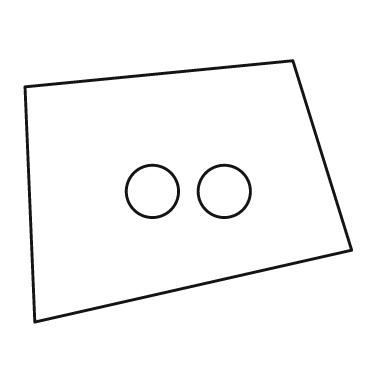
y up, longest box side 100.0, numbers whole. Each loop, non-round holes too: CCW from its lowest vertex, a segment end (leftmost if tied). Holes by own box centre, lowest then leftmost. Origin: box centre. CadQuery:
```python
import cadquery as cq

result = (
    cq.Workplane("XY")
    .moveTo(-47.0, -40.0)
    .lineTo(50.0, -18.0)
    .lineTo(32.0, 40.0)
    .lineTo(-50.0, 32.0)
    .close()
    .moveTo(-11.0, 0.0)
    .circle(8.0)
    .moveTo(11.0, 0.0)
    .circle(8.0)
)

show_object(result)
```